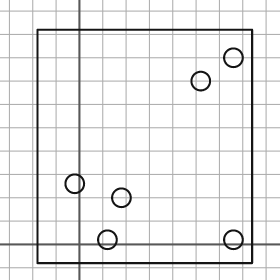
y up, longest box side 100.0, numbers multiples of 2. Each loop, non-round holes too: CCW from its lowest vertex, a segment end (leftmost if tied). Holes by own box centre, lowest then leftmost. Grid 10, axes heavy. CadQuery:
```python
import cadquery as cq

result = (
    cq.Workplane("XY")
    .moveTo(-18.0, -8.0)
    .lineTo(74.0, -8.0)
    .lineTo(74.0, 92.0)
    .lineTo(-18.0, 92.0)
    .close()
    .moveTo(12.0, 2.0)
    .circle(4.0)
    .moveTo(66.0, 2.0)
    .circle(4.0)
    .moveTo(18.0, 20.0)
    .circle(4.0)
    .moveTo(-2.0, 26.0)
    .circle(4.0)
    .moveTo(52.0, 70.0)
    .circle(4.0)
    .moveTo(66.0, 80.0)
    .circle(4.0)
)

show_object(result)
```